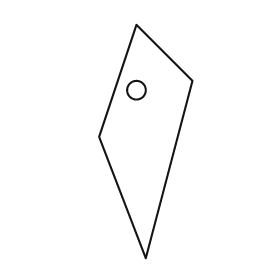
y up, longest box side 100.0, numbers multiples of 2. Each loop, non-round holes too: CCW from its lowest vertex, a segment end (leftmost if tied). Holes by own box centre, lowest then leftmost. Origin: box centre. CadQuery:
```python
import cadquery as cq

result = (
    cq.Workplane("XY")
    .moveTo(0.0, -50.0)
    .lineTo(20.0, 26.0)
    .lineTo(-4.0, 50.0)
    .lineTo(-20.0, 2.0)
    .close()
    .moveTo(-4.0, 22.0)
    .circle(4.0)
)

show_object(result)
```